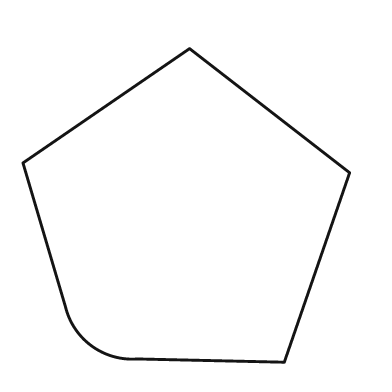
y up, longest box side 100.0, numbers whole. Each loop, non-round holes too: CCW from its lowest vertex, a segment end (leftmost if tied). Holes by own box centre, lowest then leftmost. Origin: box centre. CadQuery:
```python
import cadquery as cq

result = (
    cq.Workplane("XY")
    .moveTo(30.0, -48.0)
    .lineTo(50.0, 10.0)
    .lineTo(1.0, 48.0)
    .lineTo(-50.0, 13.0)
    .lineTo(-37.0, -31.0)
    .threePointArc((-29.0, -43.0), (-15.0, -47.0))
    .close()
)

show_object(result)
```